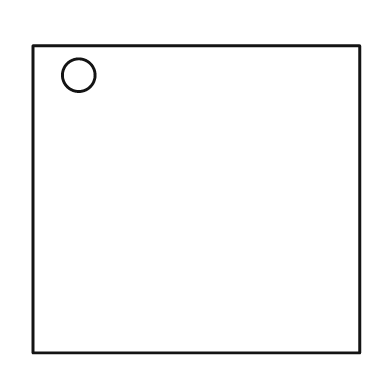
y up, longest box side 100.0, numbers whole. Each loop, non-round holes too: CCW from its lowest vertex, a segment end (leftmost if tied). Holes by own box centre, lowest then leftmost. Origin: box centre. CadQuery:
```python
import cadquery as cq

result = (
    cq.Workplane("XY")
    .moveTo(-50.0, -47.0)
    .lineTo(50.0, -47.0)
    .lineTo(50.0, 47.0)
    .lineTo(-50.0, 47.0)
    .close()
    .moveTo(-36.0, 38.0)
    .circle(5.0)
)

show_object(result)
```